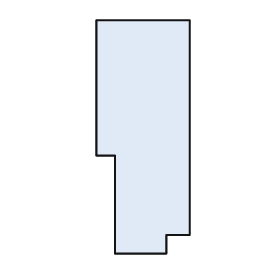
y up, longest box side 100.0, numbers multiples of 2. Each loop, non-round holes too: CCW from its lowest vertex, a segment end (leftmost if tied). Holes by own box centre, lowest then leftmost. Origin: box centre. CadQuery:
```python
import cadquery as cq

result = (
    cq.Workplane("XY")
    .moveTo(-12.0, -50.0)
    .lineTo(10.0, -50.0)
    .lineTo(10.0, -42.0)
    .lineTo(20.0, -42.0)
    .lineTo(20.0, 50.0)
    .lineTo(-20.0, 50.0)
    .lineTo(-20.0, -8.0)
    .lineTo(-12.0, -8.0)
    .close()
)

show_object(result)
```